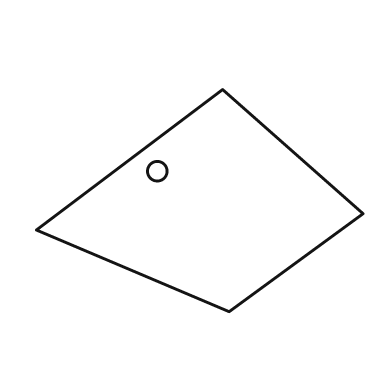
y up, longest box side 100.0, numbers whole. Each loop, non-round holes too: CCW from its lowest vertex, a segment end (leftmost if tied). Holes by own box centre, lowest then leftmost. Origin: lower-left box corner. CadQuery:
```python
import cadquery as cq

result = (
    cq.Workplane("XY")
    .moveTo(59.0, 0.0)
    .lineTo(100.0, 30.0)
    .lineTo(57.0, 68.0)
    .lineTo(0.0, 25.0)
    .close()
    .moveTo(37.0, 43.0)
    .circle(3.0)
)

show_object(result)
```